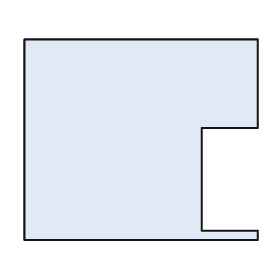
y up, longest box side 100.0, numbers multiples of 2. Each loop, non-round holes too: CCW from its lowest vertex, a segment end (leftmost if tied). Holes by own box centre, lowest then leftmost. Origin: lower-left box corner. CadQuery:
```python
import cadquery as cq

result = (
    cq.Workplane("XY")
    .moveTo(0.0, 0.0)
    .lineTo(100.0, 0.0)
    .lineTo(100.0, 4.0)
    .lineTo(76.0, 4.0)
    .lineTo(76.0, 48.0)
    .lineTo(100.0, 48.0)
    .lineTo(100.0, 86.0)
    .lineTo(0.0, 86.0)
    .close()
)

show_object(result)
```